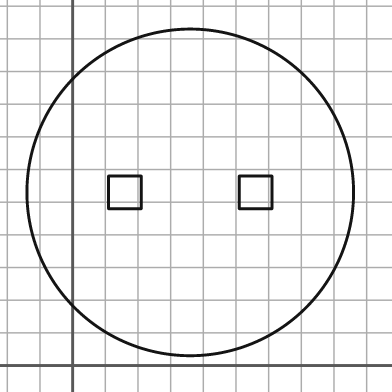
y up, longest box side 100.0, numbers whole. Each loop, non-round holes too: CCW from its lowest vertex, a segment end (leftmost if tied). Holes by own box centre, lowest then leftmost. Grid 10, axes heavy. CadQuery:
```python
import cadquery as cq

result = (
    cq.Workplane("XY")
    .moveTo(36.0, 53.0)
    .circle(50.0)
    .moveTo(11.0, 48.0)
    .lineTo(21.0, 48.0)
    .lineTo(21.0, 58.0)
    .lineTo(11.0, 58.0)
    .close()
    .moveTo(51.0, 48.0)
    .lineTo(61.0, 48.0)
    .lineTo(61.0, 58.0)
    .lineTo(51.0, 58.0)
    .close()
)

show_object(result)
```